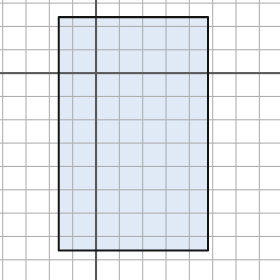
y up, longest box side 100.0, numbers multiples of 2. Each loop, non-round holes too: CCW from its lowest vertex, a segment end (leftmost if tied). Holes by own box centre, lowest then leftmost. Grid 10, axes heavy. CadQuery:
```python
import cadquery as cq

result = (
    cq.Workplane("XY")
    .moveTo(-16.0, -76.0)
    .lineTo(48.0, -76.0)
    .lineTo(48.0, 24.0)
    .lineTo(-16.0, 24.0)
    .close()
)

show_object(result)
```